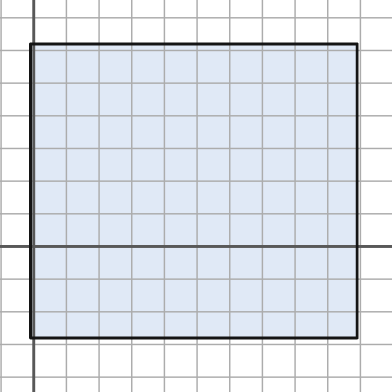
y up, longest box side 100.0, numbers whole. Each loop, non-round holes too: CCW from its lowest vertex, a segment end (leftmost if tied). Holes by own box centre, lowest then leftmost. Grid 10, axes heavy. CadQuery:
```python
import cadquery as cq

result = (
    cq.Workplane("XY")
    .moveTo(-1.0, -28.0)
    .lineTo(99.0, -28.0)
    .lineTo(99.0, 62.0)
    .lineTo(-1.0, 62.0)
    .close()
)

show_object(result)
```